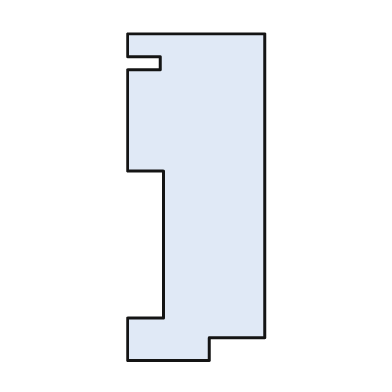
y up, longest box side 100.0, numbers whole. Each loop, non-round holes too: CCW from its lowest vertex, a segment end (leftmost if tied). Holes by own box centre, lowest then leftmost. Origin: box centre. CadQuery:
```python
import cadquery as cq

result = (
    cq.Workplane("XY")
    .moveTo(-21.0, -50.0)
    .lineTo(4.0, -50.0)
    .lineTo(4.0, -43.0)
    .lineTo(21.0, -43.0)
    .lineTo(21.0, 50.0)
    .lineTo(-21.0, 50.0)
    .lineTo(-21.0, 43.0)
    .lineTo(-11.0, 43.0)
    .lineTo(-11.0, 39.0)
    .lineTo(-21.0, 39.0)
    .lineTo(-21.0, 8.0)
    .lineTo(-10.0, 8.0)
    .lineTo(-10.0, -37.0)
    .lineTo(-21.0, -37.0)
    .close()
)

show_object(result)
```